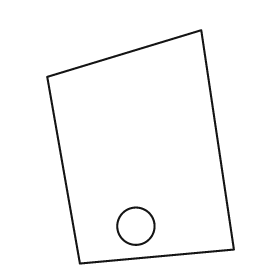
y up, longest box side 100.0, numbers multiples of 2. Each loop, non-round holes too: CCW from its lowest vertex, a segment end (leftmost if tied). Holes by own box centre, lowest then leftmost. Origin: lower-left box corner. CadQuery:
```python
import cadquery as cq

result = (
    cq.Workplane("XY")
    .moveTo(14.0, 0.0)
    .lineTo(80.0, 6.0)
    .lineTo(66.0, 100.0)
    .lineTo(0.0, 80.0)
    .close()
    .moveTo(38.0, 16.0)
    .circle(8.0)
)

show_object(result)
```